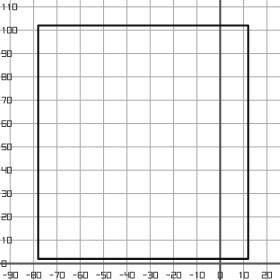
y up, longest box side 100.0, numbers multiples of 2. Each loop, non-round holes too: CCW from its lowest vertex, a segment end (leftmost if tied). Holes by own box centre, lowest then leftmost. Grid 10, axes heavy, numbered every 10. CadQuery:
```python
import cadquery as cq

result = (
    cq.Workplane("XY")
    .moveTo(-78.0, 2.0)
    .lineTo(12.0, 2.0)
    .lineTo(12.0, 102.0)
    .lineTo(-78.0, 102.0)
    .close()
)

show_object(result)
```